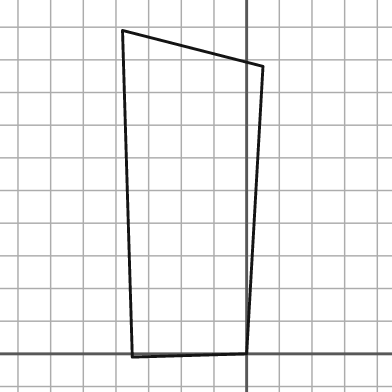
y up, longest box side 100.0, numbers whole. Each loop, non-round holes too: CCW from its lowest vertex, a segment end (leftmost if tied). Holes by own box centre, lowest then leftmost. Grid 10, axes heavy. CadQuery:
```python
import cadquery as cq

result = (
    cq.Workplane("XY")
    .moveTo(-35.0, -1.0)
    .lineTo(0.0, 0.0)
    .lineTo(5.0, 88.0)
    .lineTo(-38.0, 99.0)
    .close()
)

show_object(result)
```